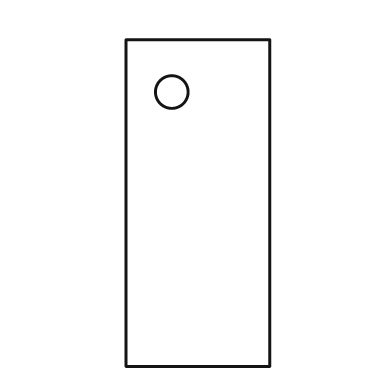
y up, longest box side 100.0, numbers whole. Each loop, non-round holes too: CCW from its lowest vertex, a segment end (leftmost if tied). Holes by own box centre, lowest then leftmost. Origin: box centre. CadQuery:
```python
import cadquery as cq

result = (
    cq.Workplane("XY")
    .moveTo(-22.0, -50.0)
    .lineTo(22.0, -50.0)
    .lineTo(22.0, 50.0)
    .lineTo(-22.0, 50.0)
    .close()
    .moveTo(-8.0, 34.0)
    .circle(5.0)
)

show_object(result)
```